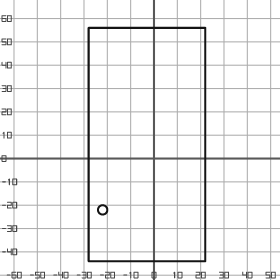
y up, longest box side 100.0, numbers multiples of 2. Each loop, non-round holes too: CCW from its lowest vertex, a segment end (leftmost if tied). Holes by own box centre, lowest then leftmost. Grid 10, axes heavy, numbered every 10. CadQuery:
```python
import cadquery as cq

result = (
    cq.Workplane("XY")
    .moveTo(-28.0, -44.0)
    .lineTo(22.0, -44.0)
    .lineTo(22.0, 56.0)
    .lineTo(-28.0, 56.0)
    .close()
    .moveTo(-22.0, -22.0)
    .circle(2.0)
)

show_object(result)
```